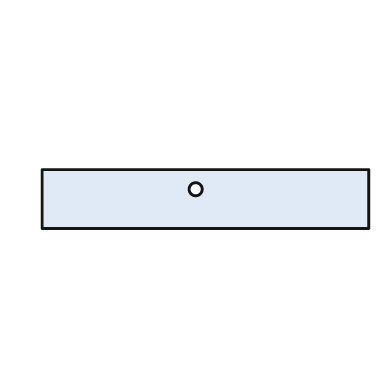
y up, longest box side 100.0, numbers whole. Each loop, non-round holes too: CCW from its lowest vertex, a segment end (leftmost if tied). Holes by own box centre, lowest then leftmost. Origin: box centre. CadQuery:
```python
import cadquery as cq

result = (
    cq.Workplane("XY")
    .moveTo(-50.0, -9.0)
    .lineTo(50.0, -9.0)
    .lineTo(50.0, 9.0)
    .lineTo(-50.0, 9.0)
    .close()
    .moveTo(-3.0, 3.0)
    .circle(2.0)
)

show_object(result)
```